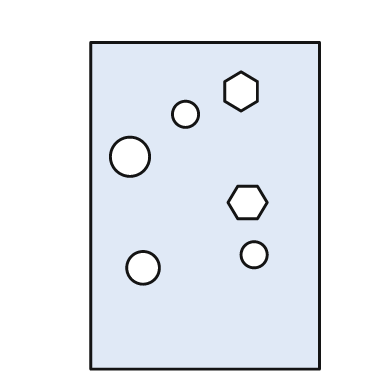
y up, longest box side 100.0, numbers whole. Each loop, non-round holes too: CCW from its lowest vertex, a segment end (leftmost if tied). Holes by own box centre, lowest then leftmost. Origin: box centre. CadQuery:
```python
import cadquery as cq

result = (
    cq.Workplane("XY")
    .moveTo(-35.0, -50.0)
    .lineTo(35.0, -50.0)
    .lineTo(35.0, 50.0)
    .lineTo(-35.0, 50.0)
    .close()
    .moveTo(-19.0, -19.0)
    .circle(5.0)
    .moveTo(15.0, -15.0)
    .circle(4.0)
    .moveTo(10.0, -4.0)
    .lineTo(16.0, -4.0)
    .lineTo(19.0, 1.0)
    .lineTo(16.0, 6.0)
    .lineTo(10.0, 6.0)
    .lineTo(7.0, 1.0)
    .close()
    .moveTo(-23.0, 15.0)
    .circle(6.0)
    .moveTo(-6.0, 28.0)
    .circle(4.0)
    .moveTo(11.0, 29.0)
    .lineTo(16.0, 32.0)
    .lineTo(16.0, 38.0)
    .lineTo(11.0, 41.0)
    .lineTo(6.0, 38.0)
    .lineTo(6.0, 32.0)
    .close()
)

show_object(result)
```